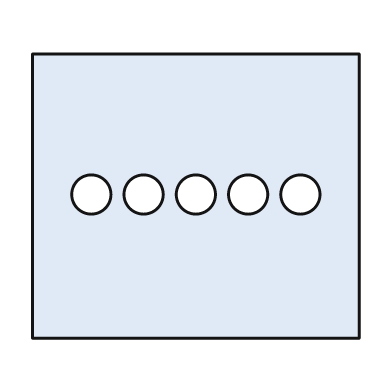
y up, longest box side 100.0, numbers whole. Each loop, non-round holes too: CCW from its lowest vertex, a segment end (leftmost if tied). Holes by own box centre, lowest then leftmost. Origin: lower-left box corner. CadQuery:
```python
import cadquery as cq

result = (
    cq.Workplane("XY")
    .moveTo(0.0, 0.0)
    .lineTo(100.0, 0.0)
    .lineTo(100.0, 87.0)
    .lineTo(0.0, 87.0)
    .close()
    .moveTo(18.0, 44.0)
    .circle(6.0)
    .moveTo(34.0, 44.0)
    .circle(6.0)
    .moveTo(50.0, 44.0)
    .circle(6.0)
    .moveTo(66.0, 44.0)
    .circle(6.0)
    .moveTo(82.0, 44.0)
    .circle(6.0)
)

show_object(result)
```